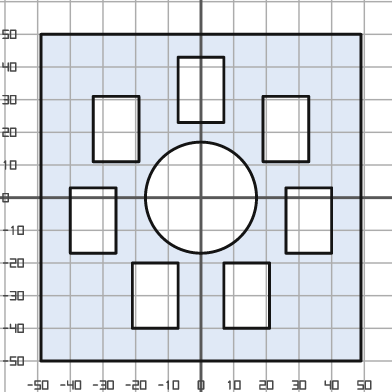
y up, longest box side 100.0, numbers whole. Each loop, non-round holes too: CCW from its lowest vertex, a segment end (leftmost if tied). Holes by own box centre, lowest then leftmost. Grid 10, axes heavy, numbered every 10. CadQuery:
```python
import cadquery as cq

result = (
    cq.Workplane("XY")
    .moveTo(-49.0, -50.0)
    .lineTo(49.0, -50.0)
    .lineTo(49.0, 50.0)
    .lineTo(-49.0, 50.0)
    .close()
    .moveTo(-21.0, -40.0)
    .lineTo(-7.0, -40.0)
    .lineTo(-7.0, -20.0)
    .lineTo(-21.0, -20.0)
    .close()
    .moveTo(7.0, -40.0)
    .lineTo(21.0, -40.0)
    .lineTo(21.0, -20.0)
    .lineTo(7.0, -20.0)
    .close()
    .moveTo(-40.0, -17.0)
    .lineTo(-26.0, -17.0)
    .lineTo(-26.0, 3.0)
    .lineTo(-40.0, 3.0)
    .close()
    .moveTo(26.0, -17.0)
    .lineTo(40.0, -17.0)
    .lineTo(40.0, 3.0)
    .lineTo(26.0, 3.0)
    .close()
    .moveTo(0.0, 0.0)
    .circle(17.0)
    .moveTo(-33.0, 11.0)
    .lineTo(-19.0, 11.0)
    .lineTo(-19.0, 31.0)
    .lineTo(-33.0, 31.0)
    .close()
    .moveTo(19.0, 11.0)
    .lineTo(33.0, 11.0)
    .lineTo(33.0, 31.0)
    .lineTo(19.0, 31.0)
    .close()
    .moveTo(-7.0, 23.0)
    .lineTo(7.0, 23.0)
    .lineTo(7.0, 43.0)
    .lineTo(-7.0, 43.0)
    .close()
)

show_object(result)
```